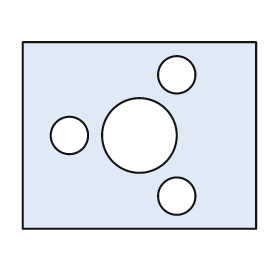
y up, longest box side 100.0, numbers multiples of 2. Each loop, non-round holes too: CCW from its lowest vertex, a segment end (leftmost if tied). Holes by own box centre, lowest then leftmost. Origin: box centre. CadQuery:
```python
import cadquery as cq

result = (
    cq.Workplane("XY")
    .moveTo(-50.0, -40.0)
    .lineTo(50.0, -40.0)
    .lineTo(50.0, 40.0)
    .lineTo(-50.0, 40.0)
    .close()
    .moveTo(16.0, -26.0)
    .circle(8.0)
    .moveTo(-30.0, 0.0)
    .circle(8.0)
    .moveTo(0.0, 0.0)
    .circle(16.0)
    .moveTo(16.0, 26.0)
    .circle(8.0)
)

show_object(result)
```